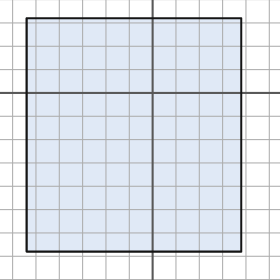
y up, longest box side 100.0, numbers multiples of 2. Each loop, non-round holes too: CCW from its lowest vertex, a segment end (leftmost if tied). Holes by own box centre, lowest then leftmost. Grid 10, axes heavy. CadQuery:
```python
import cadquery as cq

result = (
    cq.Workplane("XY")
    .moveTo(-54.0, -68.0)
    .lineTo(38.0, -68.0)
    .lineTo(38.0, 32.0)
    .lineTo(-54.0, 32.0)
    .close()
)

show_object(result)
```